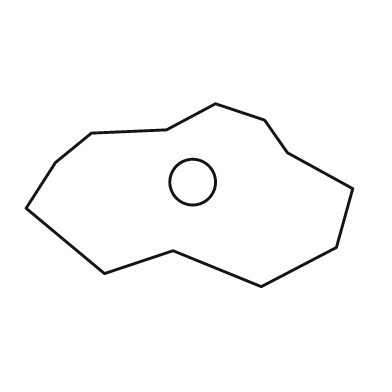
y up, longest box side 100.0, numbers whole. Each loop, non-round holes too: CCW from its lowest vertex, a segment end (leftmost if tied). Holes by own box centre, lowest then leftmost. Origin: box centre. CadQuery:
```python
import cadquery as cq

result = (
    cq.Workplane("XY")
    .moveTo(22.0, -28.0)
    .lineTo(45.0, -16.0)
    .lineTo(50.0, 2.0)
    .lineTo(30.0, 13.0)
    .lineTo(23.0, 23.0)
    .lineTo(8.0, 28.0)
    .lineTo(-7.0, 20.0)
    .lineTo(-30.0, 19.0)
    .lineTo(-41.0, 10.0)
    .lineTo(-50.0, -4.0)
    .lineTo(-26.0, -24.0)
    .lineTo(-5.0, -17.0)
    .close()
    .moveTo(1.0, 4.0)
    .circle(7.0)
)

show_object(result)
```